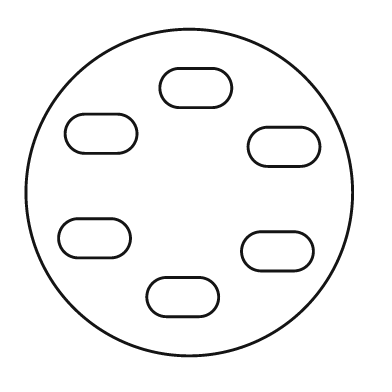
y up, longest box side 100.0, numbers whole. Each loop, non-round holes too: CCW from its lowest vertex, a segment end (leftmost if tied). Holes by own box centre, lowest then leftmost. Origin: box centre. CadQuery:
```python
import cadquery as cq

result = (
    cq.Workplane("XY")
    .moveTo(0.0, 0.0)
    .circle(50.0)
    .moveTo(-7.0, -38.0)
    .lineTo(3.0, -38.0)
    .threePointArc((9.0, -32.0), (3.0, -26.0))
    .lineTo(-7.0, -26.0)
    .threePointArc((-13.0, -32.0), (-7.0, -38.0))
    .close()
    .moveTo(22.0, -24.0)
    .lineTo(32.0, -24.0)
    .threePointArc((38.0, -18.0), (32.0, -12.0))
    .lineTo(22.0, -12.0)
    .threePointArc((16.0, -18.0), (22.0, -24.0))
    .close()
    .moveTo(-34.0, -20.0)
    .lineTo(-24.0, -20.0)
    .threePointArc((-18.0, -14.0), (-24.0, -8.0))
    .lineTo(-34.0, -8.0)
    .threePointArc((-40.0, -14.0), (-34.0, -20.0))
    .close()
    .moveTo(24.0, 8.0)
    .lineTo(34.0, 8.0)
    .threePointArc((40.0, 14.0), (34.0, 20.0))
    .lineTo(24.0, 20.0)
    .threePointArc((18.0, 14.0), (24.0, 8.0))
    .close()
    .moveTo(-32.0, 12.0)
    .lineTo(-22.0, 12.0)
    .threePointArc((-16.0, 18.0), (-22.0, 24.0))
    .lineTo(-32.0, 24.0)
    .threePointArc((-38.0, 18.0), (-32.0, 12.0))
    .close()
    .moveTo(-3.0, 26.0)
    .lineTo(7.0, 26.0)
    .threePointArc((13.0, 32.0), (7.0, 38.0))
    .lineTo(-3.0, 38.0)
    .threePointArc((-9.0, 32.0), (-3.0, 26.0))
    .close()
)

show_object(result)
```